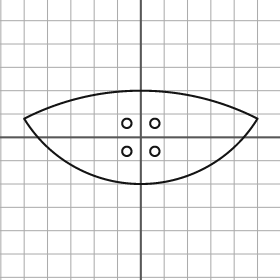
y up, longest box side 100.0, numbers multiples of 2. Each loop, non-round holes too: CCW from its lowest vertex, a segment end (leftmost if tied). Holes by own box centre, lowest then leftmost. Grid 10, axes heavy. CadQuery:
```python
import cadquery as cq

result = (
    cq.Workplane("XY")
    .moveTo(-50.0, 8.0)
    .threePointArc((0.0, -20.0), (50.0, 8.0))
    .threePointArc((0.0, 20.0), (-50.0, 8.0))
    .close()
    .moveTo(-6.0, -6.0)
    .circle(2.0)
    .moveTo(6.0, -6.0)
    .circle(2.0)
    .moveTo(-6.0, 6.0)
    .circle(2.0)
    .moveTo(6.0, 6.0)
    .circle(2.0)
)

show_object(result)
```